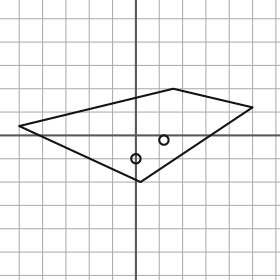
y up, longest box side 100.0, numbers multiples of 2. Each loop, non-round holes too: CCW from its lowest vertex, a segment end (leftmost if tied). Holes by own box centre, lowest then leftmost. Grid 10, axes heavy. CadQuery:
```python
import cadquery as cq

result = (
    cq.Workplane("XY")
    .moveTo(2.0, -20.0)
    .lineTo(50.0, 12.0)
    .lineTo(16.0, 20.0)
    .lineTo(-50.0, 4.0)
    .close()
    .moveTo(0.0, -10.0)
    .circle(2.0)
    .moveTo(12.0, -2.0)
    .circle(2.0)
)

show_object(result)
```